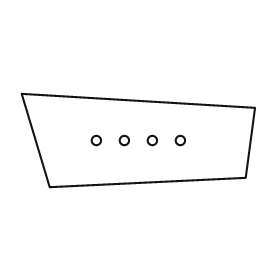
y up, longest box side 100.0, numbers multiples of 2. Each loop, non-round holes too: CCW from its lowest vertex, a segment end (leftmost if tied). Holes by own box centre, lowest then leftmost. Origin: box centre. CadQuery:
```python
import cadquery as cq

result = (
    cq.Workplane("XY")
    .moveTo(-38.0, -20.0)
    .lineTo(46.0, -16.0)
    .lineTo(50.0, 14.0)
    .lineTo(-50.0, 20.0)
    .close()
    .moveTo(-18.0, 0.0)
    .circle(2.0)
    .moveTo(-6.0, 0.0)
    .circle(2.0)
    .moveTo(6.0, 0.0)
    .circle(2.0)
    .moveTo(18.0, 0.0)
    .circle(2.0)
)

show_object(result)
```